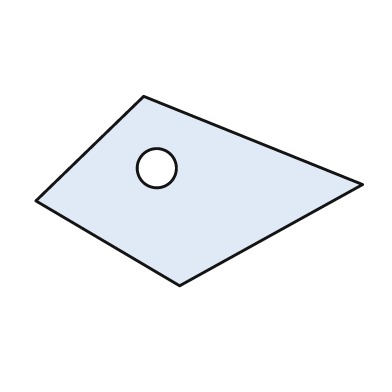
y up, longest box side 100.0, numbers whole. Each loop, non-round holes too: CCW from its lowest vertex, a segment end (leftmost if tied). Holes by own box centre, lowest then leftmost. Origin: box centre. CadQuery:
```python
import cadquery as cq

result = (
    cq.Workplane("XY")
    .moveTo(-6.0, -29.0)
    .lineTo(50.0, 2.0)
    .lineTo(-17.0, 29.0)
    .lineTo(-50.0, -3.0)
    .close()
    .moveTo(-13.0, 7.0)
    .circle(6.0)
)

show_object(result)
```